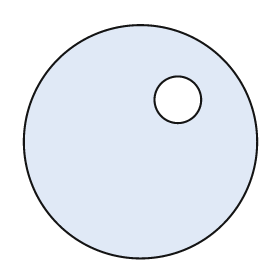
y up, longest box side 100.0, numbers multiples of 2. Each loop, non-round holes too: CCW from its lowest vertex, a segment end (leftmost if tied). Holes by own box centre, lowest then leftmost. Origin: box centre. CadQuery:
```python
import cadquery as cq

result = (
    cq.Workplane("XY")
    .moveTo(0.0, 0.0)
    .circle(50.0)
    .moveTo(16.0, 18.0)
    .circle(10.0)
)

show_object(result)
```